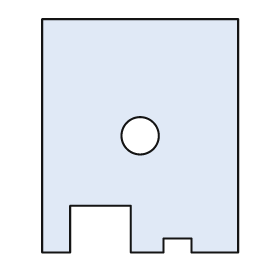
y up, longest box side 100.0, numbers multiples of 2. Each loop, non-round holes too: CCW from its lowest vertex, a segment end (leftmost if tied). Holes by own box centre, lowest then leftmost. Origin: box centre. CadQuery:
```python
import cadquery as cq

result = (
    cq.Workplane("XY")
    .moveTo(-42.0, -50.0)
    .lineTo(-30.0, -50.0)
    .lineTo(-30.0, -30.0)
    .lineTo(-4.0, -30.0)
    .lineTo(-4.0, -50.0)
    .lineTo(10.0, -50.0)
    .lineTo(10.0, -44.0)
    .lineTo(22.0, -44.0)
    .lineTo(22.0, -50.0)
    .lineTo(42.0, -50.0)
    .lineTo(42.0, 50.0)
    .lineTo(-42.0, 50.0)
    .close()
    .moveTo(0.0, 0.0)
    .circle(8.0)
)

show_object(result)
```